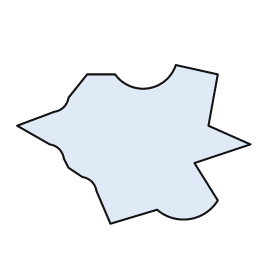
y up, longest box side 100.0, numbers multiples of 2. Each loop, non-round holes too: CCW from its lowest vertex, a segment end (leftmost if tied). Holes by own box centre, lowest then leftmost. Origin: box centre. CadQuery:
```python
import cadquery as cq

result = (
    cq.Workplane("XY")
    .moveTo(-10.0, -34.0)
    .lineTo(10.0, -28.0)
    .threePointArc((24.0, -32.0), (36.0, -24.0))
    .lineTo(26.0, -8.0)
    .lineTo(50.0, 0.0)
    .lineTo(32.0, 8.0)
    .lineTo(36.0, 30.0)
    .lineTo(18.0, 34.0)
    .threePointArc((6.0, 24.0), (-8.0, 30.0))
    .lineTo(-20.0, 30.0)
    .lineTo(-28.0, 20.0)
    .threePointArc((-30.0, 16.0), (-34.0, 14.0))
    .lineTo(-50.0, 8.0)
    .lineTo(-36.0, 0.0)
    .threePointArc((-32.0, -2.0), (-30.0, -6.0))
    .lineTo(-28.0, -10.0)
    .lineTo(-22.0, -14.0)
    .threePointArc((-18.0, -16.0), (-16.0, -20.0))
    .close()
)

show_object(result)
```